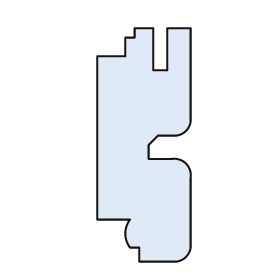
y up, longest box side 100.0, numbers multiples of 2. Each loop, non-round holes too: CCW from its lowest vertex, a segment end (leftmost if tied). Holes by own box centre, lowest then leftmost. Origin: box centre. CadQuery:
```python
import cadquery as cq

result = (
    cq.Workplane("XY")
    .moveTo(-2.0, -50.0)
    .lineTo(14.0, -50.0)
    .threePointArc((18.0, -48.0), (20.0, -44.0))
    .lineTo(20.0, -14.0)
    .threePointArc((18.0, -8.0), (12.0, -6.0))
    .lineTo(2.0, -6.0)
    .lineTo(2.0, 0.0)
    .lineTo(6.0, 4.0)
    .lineTo(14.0, 4.0)
    .threePointArc((18.0, 6.0), (20.0, 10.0))
    .lineTo(20.0, 50.0)
    .lineTo(10.0, 50.0)
    .lineTo(10.0, 32.0)
    .lineTo(4.0, 32.0)
    .lineTo(4.0, 50.0)
    .lineTo(-4.0, 50.0)
    .lineTo(-4.0, 46.0)
    .lineTo(-8.0, 46.0)
    .lineTo(-8.0, 38.0)
    .lineTo(-20.0, 38.0)
    .lineTo(-20.0, -32.0)
    .lineTo(-6.0, -32.0)
    .threePointArc((-8.0, -38.0), (-6.0, -44.0))
    .lineTo(-2.0, -44.0)
    .close()
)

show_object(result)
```